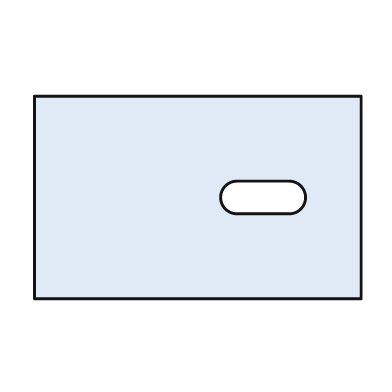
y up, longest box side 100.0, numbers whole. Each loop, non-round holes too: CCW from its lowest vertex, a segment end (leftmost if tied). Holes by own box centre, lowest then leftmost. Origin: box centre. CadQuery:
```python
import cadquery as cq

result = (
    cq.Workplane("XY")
    .moveTo(-50.0, -31.0)
    .lineTo(50.0, -31.0)
    .lineTo(50.0, 31.0)
    .lineTo(-50.0, 31.0)
    .close()
    .moveTo(12.0, -5.0)
    .lineTo(28.0, -5.0)
    .threePointArc((33.0, 0.0), (28.0, 5.0))
    .lineTo(12.0, 5.0)
    .threePointArc((7.0, 0.0), (12.0, -5.0))
    .close()
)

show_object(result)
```